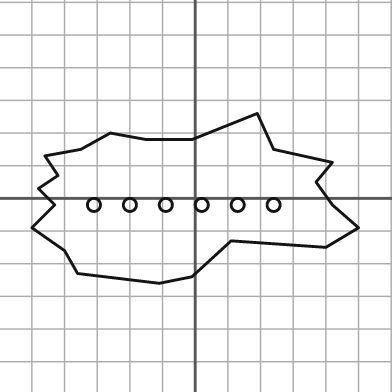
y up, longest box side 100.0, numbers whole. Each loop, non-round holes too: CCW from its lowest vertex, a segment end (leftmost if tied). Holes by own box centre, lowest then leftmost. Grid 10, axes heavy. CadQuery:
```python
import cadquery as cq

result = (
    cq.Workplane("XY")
    .moveTo(-11.0, -26.0)
    .lineTo(-1.0, -24.0)
    .lineTo(11.0, -13.0)
    .lineTo(40.0, -15.0)
    .lineTo(50.0, -9.0)
    .lineTo(42.0, -2.0)
    .lineTo(37.0, 5.0)
    .lineTo(42.0, 11.0)
    .lineTo(24.0, 15.0)
    .lineTo(19.0, 26.0)
    .lineTo(-1.0, 18.0)
    .lineTo(-15.0, 18.0)
    .lineTo(-26.0, 20.0)
    .lineTo(-35.0, 15.0)
    .lineTo(-46.0, 13.0)
    .lineTo(-42.0, 7.0)
    .lineTo(-48.0, 3.0)
    .lineTo(-43.0, -2.0)
    .lineTo(-50.0, -9.0)
    .lineTo(-40.0, -16.0)
    .lineTo(-36.0, -23.0)
    .close()
    .moveTo(-31.0, -2.0)
    .circle(2.0)
    .moveTo(-20.0, -2.0)
    .circle(2.0)
    .moveTo(-9.0, -2.0)
    .circle(2.0)
    .moveTo(2.0, -2.0)
    .circle(2.0)
    .moveTo(13.0, -2.0)
    .circle(2.0)
    .moveTo(24.0, -2.0)
    .circle(2.0)
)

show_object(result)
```